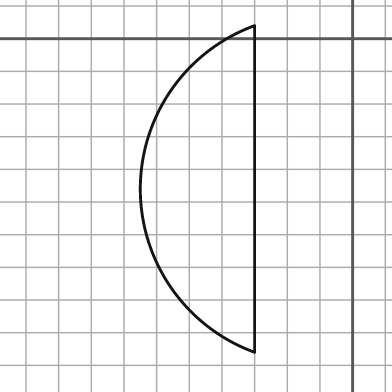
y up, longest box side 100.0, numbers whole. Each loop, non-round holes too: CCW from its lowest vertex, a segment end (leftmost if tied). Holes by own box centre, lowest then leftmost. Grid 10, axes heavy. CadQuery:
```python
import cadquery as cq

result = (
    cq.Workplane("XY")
    .moveTo(-30.0, -96.0)
    .lineTo(-30.0, 4.0)
    .threePointArc((-65.0, -46.0), (-30.0, -96.0))
    .close()
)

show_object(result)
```